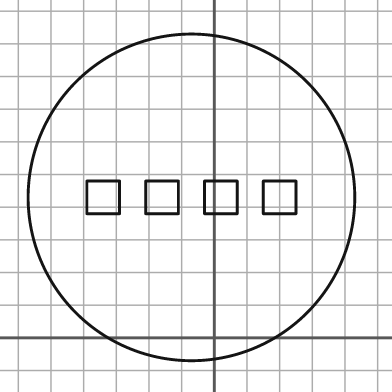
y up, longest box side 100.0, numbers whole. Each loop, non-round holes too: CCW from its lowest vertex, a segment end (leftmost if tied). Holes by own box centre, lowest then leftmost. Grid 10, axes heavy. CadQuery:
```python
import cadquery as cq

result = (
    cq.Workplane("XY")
    .moveTo(-7.0, 43.0)
    .circle(50.0)
    .moveTo(-39.0, 38.0)
    .lineTo(-29.0, 38.0)
    .lineTo(-29.0, 48.0)
    .lineTo(-39.0, 48.0)
    .close()
    .moveTo(-21.0, 38.0)
    .lineTo(-11.0, 38.0)
    .lineTo(-11.0, 48.0)
    .lineTo(-21.0, 48.0)
    .close()
    .moveTo(-3.0, 38.0)
    .lineTo(7.0, 38.0)
    .lineTo(7.0, 48.0)
    .lineTo(-3.0, 48.0)
    .close()
    .moveTo(15.0, 38.0)
    .lineTo(25.0, 38.0)
    .lineTo(25.0, 48.0)
    .lineTo(15.0, 48.0)
    .close()
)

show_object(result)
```